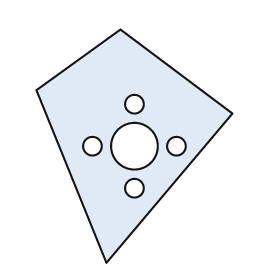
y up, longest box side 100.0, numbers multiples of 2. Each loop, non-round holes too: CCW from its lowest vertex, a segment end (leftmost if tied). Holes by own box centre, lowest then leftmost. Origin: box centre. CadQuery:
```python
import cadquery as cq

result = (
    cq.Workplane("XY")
    .moveTo(-12.0, -50.0)
    .lineTo(42.0, 14.0)
    .lineTo(-6.0, 50.0)
    .lineTo(-42.0, 24.0)
    .close()
    .moveTo(0.0, -18.0)
    .circle(4.0)
    .moveTo(-18.0, 0.0)
    .circle(4.0)
    .moveTo(0.0, 0.0)
    .circle(10.0)
    .moveTo(18.0, 0.0)
    .circle(4.0)
    .moveTo(0.0, 18.0)
    .circle(4.0)
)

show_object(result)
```